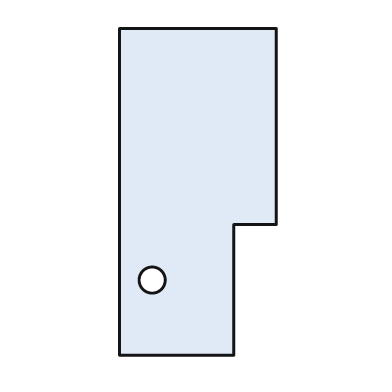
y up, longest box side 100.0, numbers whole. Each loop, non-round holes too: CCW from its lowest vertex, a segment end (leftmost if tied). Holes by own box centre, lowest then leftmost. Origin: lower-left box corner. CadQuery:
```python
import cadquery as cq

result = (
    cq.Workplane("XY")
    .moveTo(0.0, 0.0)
    .lineTo(35.0, 0.0)
    .lineTo(35.0, 40.0)
    .lineTo(48.0, 40.0)
    .lineTo(48.0, 100.0)
    .lineTo(0.0, 100.0)
    .close()
    .moveTo(10.0, 23.0)
    .circle(4.0)
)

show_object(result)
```